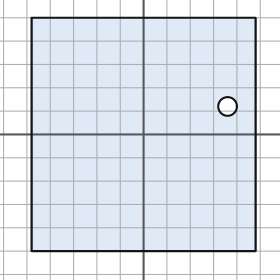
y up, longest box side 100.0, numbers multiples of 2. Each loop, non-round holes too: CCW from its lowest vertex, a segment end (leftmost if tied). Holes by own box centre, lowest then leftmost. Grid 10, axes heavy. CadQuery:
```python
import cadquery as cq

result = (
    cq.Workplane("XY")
    .moveTo(-48.0, -50.0)
    .lineTo(48.0, -50.0)
    .lineTo(48.0, 50.0)
    .lineTo(-48.0, 50.0)
    .close()
    .moveTo(36.0, 12.0)
    .circle(4.0)
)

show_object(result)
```